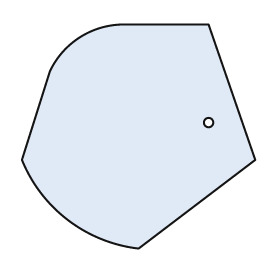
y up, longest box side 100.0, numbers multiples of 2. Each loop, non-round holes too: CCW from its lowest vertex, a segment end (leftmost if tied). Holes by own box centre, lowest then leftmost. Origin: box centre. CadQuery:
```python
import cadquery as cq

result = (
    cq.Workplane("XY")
    .moveTo(0.0, -48.0)
    .lineTo(50.0, -10.0)
    .lineTo(30.0, 48.0)
    .lineTo(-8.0, 48.0)
    .threePointArc((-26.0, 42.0), (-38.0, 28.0))
    .lineTo(-50.0, -10.0)
    .threePointArc((-30.0, -36.0), (0.0, -48.0))
    .close()
    .moveTo(30.0, 6.0)
    .circle(2.0)
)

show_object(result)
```